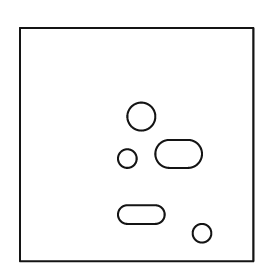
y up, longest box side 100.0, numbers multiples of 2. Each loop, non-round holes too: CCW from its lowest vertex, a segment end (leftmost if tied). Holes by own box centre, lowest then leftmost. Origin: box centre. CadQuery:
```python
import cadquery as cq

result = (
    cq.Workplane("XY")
    .moveTo(-50.0, -50.0)
    .lineTo(50.0, -50.0)
    .lineTo(50.0, 50.0)
    .lineTo(-50.0, 50.0)
    .close()
    .moveTo(28.0, -38.0)
    .circle(4.0)
    .moveTo(-4.0, -34.0)
    .lineTo(8.0, -34.0)
    .threePointArc((12.0, -30.0), (8.0, -26.0))
    .lineTo(-4.0, -26.0)
    .threePointArc((-8.0, -30.0), (-4.0, -34.0))
    .close()
    .moveTo(-4.0, -6.0)
    .circle(4.0)
    .moveTo(14.0, -10.0)
    .lineTo(22.0, -10.0)
    .threePointArc((28.0, -4.0), (22.0, 2.0))
    .lineTo(14.0, 2.0)
    .threePointArc((8.0, -4.0), (14.0, -10.0))
    .close()
    .moveTo(2.0, 12.0)
    .circle(6.0)
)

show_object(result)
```